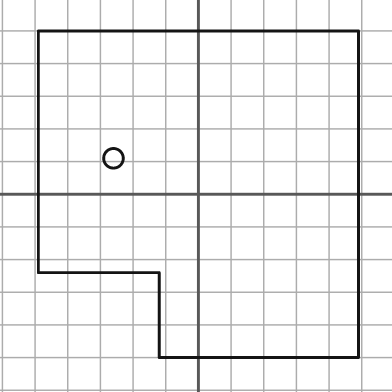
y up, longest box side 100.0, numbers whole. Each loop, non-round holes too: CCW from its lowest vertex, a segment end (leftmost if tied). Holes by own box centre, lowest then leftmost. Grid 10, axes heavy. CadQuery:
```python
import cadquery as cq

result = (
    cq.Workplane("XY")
    .moveTo(-12.0, -50.0)
    .lineTo(49.0, -50.0)
    .lineTo(49.0, 50.0)
    .lineTo(-49.0, 50.0)
    .lineTo(-49.0, -24.0)
    .lineTo(-12.0, -24.0)
    .close()
    .moveTo(-26.0, 11.0)
    .circle(3.0)
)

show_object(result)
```